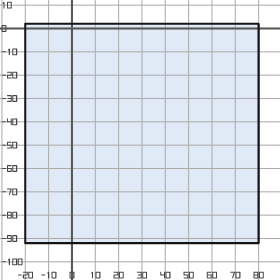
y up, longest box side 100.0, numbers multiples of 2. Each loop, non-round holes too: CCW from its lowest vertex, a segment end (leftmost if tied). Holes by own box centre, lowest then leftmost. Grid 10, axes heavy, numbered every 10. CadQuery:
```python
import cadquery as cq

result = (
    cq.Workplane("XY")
    .moveTo(-20.0, -92.0)
    .lineTo(80.0, -92.0)
    .lineTo(80.0, 2.0)
    .lineTo(-20.0, 2.0)
    .close()
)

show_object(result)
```